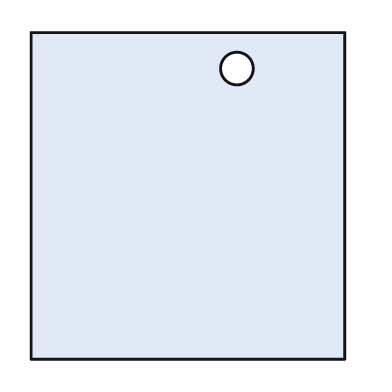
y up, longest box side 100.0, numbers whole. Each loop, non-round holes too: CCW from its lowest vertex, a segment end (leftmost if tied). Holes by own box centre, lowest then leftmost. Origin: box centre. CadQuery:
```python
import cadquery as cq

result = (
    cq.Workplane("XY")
    .moveTo(-48.0, -50.0)
    .lineTo(48.0, -50.0)
    .lineTo(48.0, 50.0)
    .lineTo(-48.0, 50.0)
    .close()
    .moveTo(15.0, 39.0)
    .circle(5.0)
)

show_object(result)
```